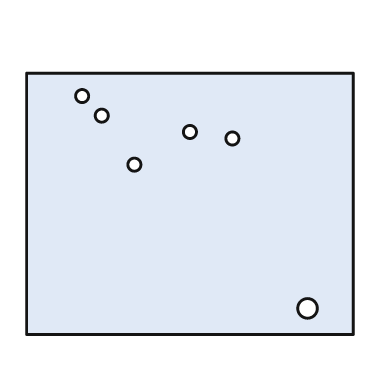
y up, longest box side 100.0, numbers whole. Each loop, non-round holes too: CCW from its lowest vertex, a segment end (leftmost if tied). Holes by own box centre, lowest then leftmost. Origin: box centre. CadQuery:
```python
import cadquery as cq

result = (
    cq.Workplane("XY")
    .moveTo(-50.0, -40.0)
    .lineTo(50.0, -40.0)
    .lineTo(50.0, 40.0)
    .lineTo(-50.0, 40.0)
    .close()
    .moveTo(36.0, -32.0)
    .circle(3.0)
    .moveTo(-17.0, 12.0)
    .circle(2.0)
    .moveTo(13.0, 20.0)
    .circle(2.0)
    .moveTo(0.0, 22.0)
    .circle(2.0)
    .moveTo(-27.0, 27.0)
    .circle(2.0)
    .moveTo(-33.0, 33.0)
    .circle(2.0)
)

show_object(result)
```